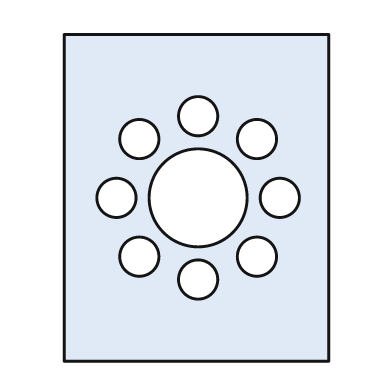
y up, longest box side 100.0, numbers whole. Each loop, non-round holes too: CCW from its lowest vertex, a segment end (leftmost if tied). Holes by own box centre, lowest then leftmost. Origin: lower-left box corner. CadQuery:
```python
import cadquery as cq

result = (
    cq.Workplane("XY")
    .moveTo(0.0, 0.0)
    .lineTo(81.0, 0.0)
    .lineTo(81.0, 100.0)
    .lineTo(0.0, 100.0)
    .close()
    .moveTo(41.0, 25.0)
    .circle(6.0)
    .moveTo(23.0, 32.0)
    .circle(6.0)
    .moveTo(59.0, 32.0)
    .circle(6.0)
    .moveTo(16.0, 50.0)
    .circle(6.0)
    .moveTo(41.0, 50.0)
    .circle(15.0)
    .moveTo(66.0, 50.0)
    .circle(6.0)
    .moveTo(23.0, 68.0)
    .circle(6.0)
    .moveTo(59.0, 68.0)
    .circle(6.0)
    .moveTo(41.0, 75.0)
    .circle(6.0)
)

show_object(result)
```